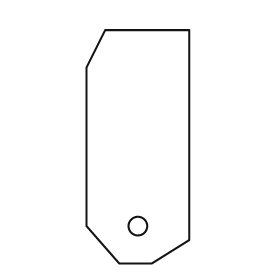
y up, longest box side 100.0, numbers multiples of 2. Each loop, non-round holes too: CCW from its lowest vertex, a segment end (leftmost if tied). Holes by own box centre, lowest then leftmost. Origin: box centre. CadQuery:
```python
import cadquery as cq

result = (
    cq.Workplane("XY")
    .moveTo(-8.0, -50.0)
    .lineTo(6.0, -50.0)
    .lineTo(22.0, -40.0)
    .lineTo(22.0, 50.0)
    .lineTo(-14.0, 50.0)
    .lineTo(-22.0, 34.0)
    .lineTo(-22.0, -34.0)
    .close()
    .moveTo(0.0, -34.0)
    .circle(4.0)
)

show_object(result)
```